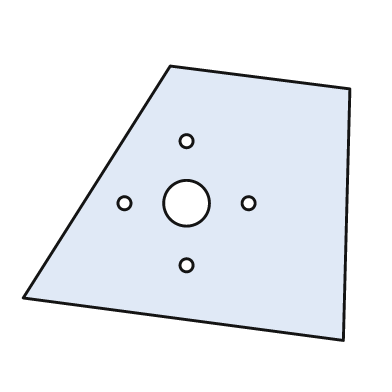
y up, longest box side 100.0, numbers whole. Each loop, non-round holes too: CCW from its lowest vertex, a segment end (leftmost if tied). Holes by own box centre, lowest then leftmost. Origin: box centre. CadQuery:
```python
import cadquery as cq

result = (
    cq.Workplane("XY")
    .moveTo(48.0, -42.0)
    .lineTo(50.0, 35.0)
    .lineTo(-5.0, 42.0)
    .lineTo(-50.0, -29.0)
    .close()
    .moveTo(0.0, -19.0)
    .circle(2.0)
    .moveTo(-19.0, 0.0)
    .circle(2.0)
    .moveTo(0.0, 0.0)
    .circle(7.0)
    .moveTo(19.0, 0.0)
    .circle(2.0)
    .moveTo(0.0, 19.0)
    .circle(2.0)
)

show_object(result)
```